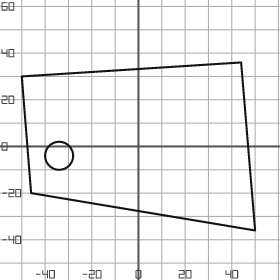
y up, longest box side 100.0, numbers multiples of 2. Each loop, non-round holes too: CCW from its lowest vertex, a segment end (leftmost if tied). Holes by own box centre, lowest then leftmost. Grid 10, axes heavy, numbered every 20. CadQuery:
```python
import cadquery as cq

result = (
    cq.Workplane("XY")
    .moveTo(50.0, -36.0)
    .lineTo(44.0, 36.0)
    .lineTo(-50.0, 30.0)
    .lineTo(-46.0, -20.0)
    .close()
    .moveTo(-34.0, -4.0)
    .circle(6.0)
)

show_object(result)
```